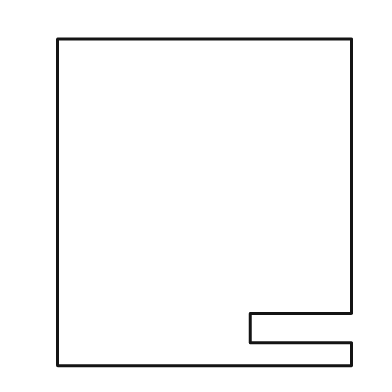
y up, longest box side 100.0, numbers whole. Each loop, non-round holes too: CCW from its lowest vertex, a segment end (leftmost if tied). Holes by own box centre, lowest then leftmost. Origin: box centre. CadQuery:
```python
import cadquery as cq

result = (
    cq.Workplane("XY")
    .moveTo(-45.0, -50.0)
    .lineTo(45.0, -50.0)
    .lineTo(45.0, -43.0)
    .lineTo(14.0, -43.0)
    .lineTo(14.0, -34.0)
    .lineTo(45.0, -34.0)
    .lineTo(45.0, 50.0)
    .lineTo(-45.0, 50.0)
    .close()
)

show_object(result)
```